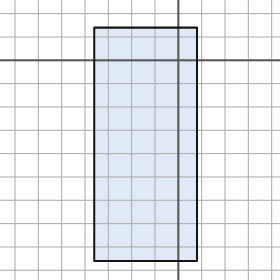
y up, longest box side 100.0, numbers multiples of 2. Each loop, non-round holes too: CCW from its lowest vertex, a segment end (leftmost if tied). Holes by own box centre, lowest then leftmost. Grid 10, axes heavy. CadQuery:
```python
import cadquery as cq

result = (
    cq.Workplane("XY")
    .moveTo(-36.0, -86.0)
    .lineTo(8.0, -86.0)
    .lineTo(8.0, 14.0)
    .lineTo(-36.0, 14.0)
    .close()
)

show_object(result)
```